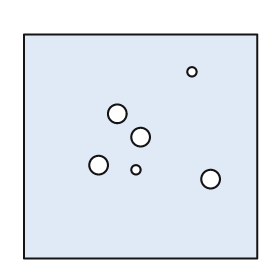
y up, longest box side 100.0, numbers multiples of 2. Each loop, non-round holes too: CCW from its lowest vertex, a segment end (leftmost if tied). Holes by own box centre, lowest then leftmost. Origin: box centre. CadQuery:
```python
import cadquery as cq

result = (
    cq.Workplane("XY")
    .moveTo(-50.0, -48.0)
    .lineTo(50.0, -48.0)
    .lineTo(50.0, 48.0)
    .lineTo(-50.0, 48.0)
    .close()
    .moveTo(30.0, -14.0)
    .circle(4.0)
    .moveTo(-2.0, -10.0)
    .circle(2.0)
    .moveTo(-18.0, -8.0)
    .circle(4.0)
    .moveTo(0.0, 4.0)
    .circle(4.0)
    .moveTo(-10.0, 14.0)
    .circle(4.0)
    .moveTo(22.0, 32.0)
    .circle(2.0)
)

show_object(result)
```